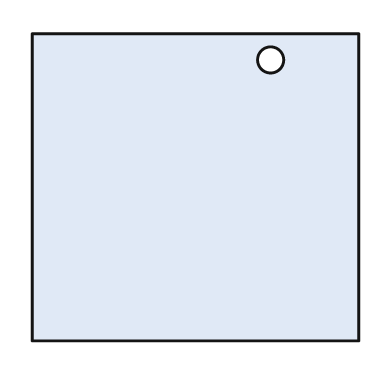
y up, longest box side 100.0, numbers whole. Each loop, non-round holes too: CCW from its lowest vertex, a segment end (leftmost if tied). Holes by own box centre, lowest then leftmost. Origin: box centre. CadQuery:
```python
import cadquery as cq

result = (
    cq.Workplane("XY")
    .moveTo(-50.0, -47.0)
    .lineTo(50.0, -47.0)
    .lineTo(50.0, 47.0)
    .lineTo(-50.0, 47.0)
    .close()
    .moveTo(23.0, 39.0)
    .circle(4.0)
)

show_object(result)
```